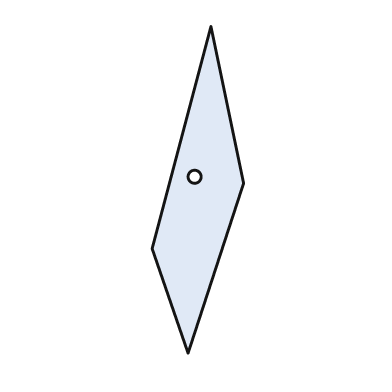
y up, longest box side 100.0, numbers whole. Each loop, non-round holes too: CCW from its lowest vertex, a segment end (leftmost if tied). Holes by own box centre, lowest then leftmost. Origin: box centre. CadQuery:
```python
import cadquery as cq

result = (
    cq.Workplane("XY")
    .moveTo(-3.0, -50.0)
    .lineTo(14.0, 2.0)
    .lineTo(4.0, 50.0)
    .lineTo(-14.0, -18.0)
    .close()
    .moveTo(-1.0, 4.0)
    .circle(2.0)
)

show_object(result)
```